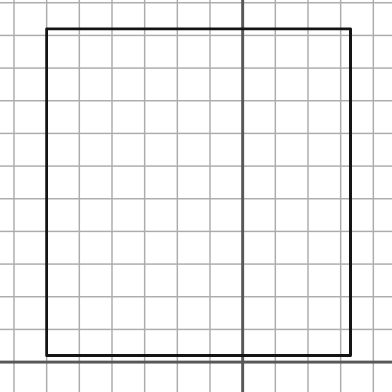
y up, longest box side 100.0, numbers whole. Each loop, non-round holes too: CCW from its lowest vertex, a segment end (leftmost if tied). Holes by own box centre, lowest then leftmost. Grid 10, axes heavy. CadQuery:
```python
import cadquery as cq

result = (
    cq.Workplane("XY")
    .moveTo(-60.0, 2.0)
    .lineTo(33.0, 2.0)
    .lineTo(33.0, 102.0)
    .lineTo(-60.0, 102.0)
    .close()
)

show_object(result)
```